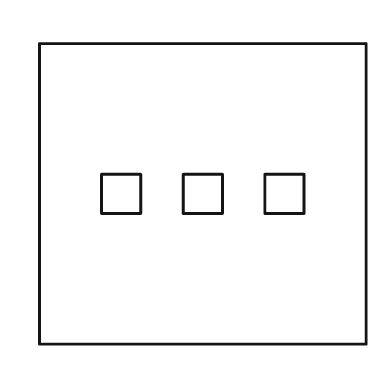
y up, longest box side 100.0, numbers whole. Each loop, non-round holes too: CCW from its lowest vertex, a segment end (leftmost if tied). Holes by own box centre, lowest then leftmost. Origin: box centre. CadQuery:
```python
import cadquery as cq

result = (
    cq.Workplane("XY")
    .moveTo(-50.0, -46.0)
    .lineTo(50.0, -46.0)
    .lineTo(50.0, 46.0)
    .lineTo(-50.0, 46.0)
    .close()
    .moveTo(-31.0, -6.0)
    .lineTo(-19.0, -6.0)
    .lineTo(-19.0, 6.0)
    .lineTo(-31.0, 6.0)
    .close()
    .moveTo(-6.0, -6.0)
    .lineTo(6.0, -6.0)
    .lineTo(6.0, 6.0)
    .lineTo(-6.0, 6.0)
    .close()
    .moveTo(19.0, -6.0)
    .lineTo(31.0, -6.0)
    .lineTo(31.0, 6.0)
    .lineTo(19.0, 6.0)
    .close()
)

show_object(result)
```